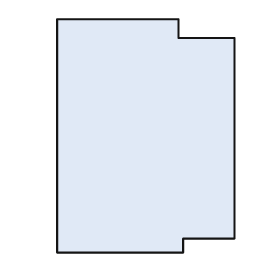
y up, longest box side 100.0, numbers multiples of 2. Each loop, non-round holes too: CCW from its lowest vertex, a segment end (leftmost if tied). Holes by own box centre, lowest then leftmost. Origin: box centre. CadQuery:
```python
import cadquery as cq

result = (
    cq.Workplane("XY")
    .moveTo(-38.0, -50.0)
    .lineTo(16.0, -50.0)
    .lineTo(16.0, -44.0)
    .lineTo(38.0, -44.0)
    .lineTo(38.0, 42.0)
    .lineTo(14.0, 42.0)
    .lineTo(14.0, 50.0)
    .lineTo(-38.0, 50.0)
    .close()
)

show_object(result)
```